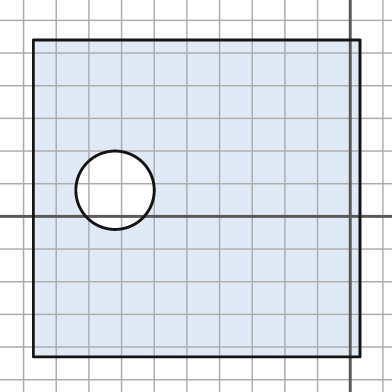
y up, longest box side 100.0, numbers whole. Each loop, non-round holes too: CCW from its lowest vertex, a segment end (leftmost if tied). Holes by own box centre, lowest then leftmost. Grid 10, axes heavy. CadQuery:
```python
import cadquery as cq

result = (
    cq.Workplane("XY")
    .moveTo(-97.0, -43.0)
    .lineTo(3.0, -43.0)
    .lineTo(3.0, 54.0)
    .lineTo(-97.0, 54.0)
    .close()
    .moveTo(-72.0, 8.0)
    .circle(12.0)
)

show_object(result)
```